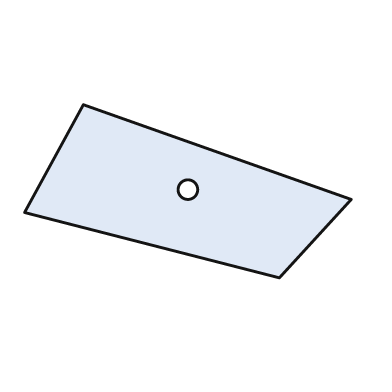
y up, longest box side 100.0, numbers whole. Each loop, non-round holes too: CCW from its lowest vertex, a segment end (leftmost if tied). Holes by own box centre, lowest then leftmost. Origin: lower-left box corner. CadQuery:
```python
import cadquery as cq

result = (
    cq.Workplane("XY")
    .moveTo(78.0, 0.0)
    .lineTo(100.0, 24.0)
    .lineTo(18.0, 53.0)
    .lineTo(0.0, 20.0)
    .close()
    .moveTo(50.0, 27.0)
    .circle(3.0)
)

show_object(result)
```